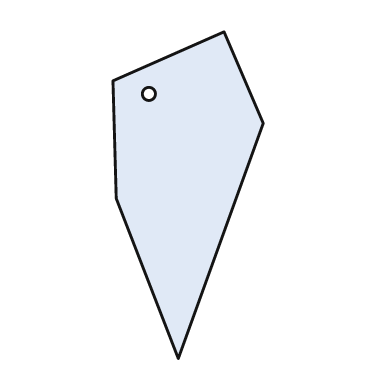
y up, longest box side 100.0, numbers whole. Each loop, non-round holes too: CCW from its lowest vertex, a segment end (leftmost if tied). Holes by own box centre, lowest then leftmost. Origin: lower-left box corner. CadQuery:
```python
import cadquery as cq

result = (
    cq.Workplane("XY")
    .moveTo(20.0, 0.0)
    .lineTo(46.0, 72.0)
    .lineTo(34.0, 100.0)
    .lineTo(0.0, 85.0)
    .lineTo(1.0, 49.0)
    .close()
    .moveTo(11.0, 81.0)
    .circle(2.0)
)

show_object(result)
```